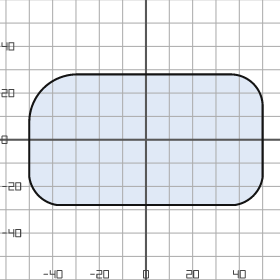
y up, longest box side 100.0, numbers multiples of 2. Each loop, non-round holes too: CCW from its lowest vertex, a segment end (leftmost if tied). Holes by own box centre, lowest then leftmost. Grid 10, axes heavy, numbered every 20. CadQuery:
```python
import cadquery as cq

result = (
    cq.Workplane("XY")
    .moveTo(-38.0, -28.0)
    .lineTo(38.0, -28.0)
    .threePointArc((46.0, -24.0), (50.0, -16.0))
    .lineTo(50.0, 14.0)
    .threePointArc((46.0, 24.0), (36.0, 28.0))
    .lineTo(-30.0, 28.0)
    .threePointArc((-44.0, 22.0), (-50.0, 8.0))
    .lineTo(-50.0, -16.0)
    .threePointArc((-46.0, -24.0), (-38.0, -28.0))
    .close()
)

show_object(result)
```